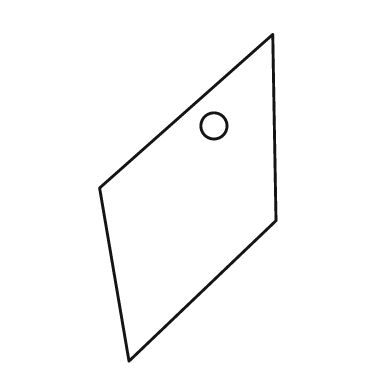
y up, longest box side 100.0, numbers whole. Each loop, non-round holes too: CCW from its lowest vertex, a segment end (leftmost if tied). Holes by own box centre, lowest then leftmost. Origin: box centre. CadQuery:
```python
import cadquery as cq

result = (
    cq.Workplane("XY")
    .moveTo(-18.0, -50.0)
    .lineTo(27.0, -7.0)
    .lineTo(26.0, 50.0)
    .lineTo(-27.0, 3.0)
    .close()
    .moveTo(8.0, 22.0)
    .circle(4.0)
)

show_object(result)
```